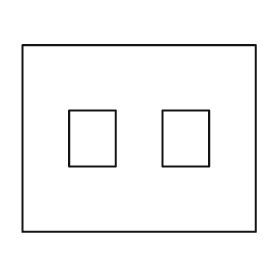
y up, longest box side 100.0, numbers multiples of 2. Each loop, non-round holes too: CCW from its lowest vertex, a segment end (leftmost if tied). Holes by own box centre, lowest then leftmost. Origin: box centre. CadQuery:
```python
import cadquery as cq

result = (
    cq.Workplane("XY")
    .moveTo(-50.0, -40.0)
    .lineTo(50.0, -40.0)
    .lineTo(50.0, 40.0)
    .lineTo(-50.0, 40.0)
    .close()
    .moveTo(-30.0, -12.0)
    .lineTo(-10.0, -12.0)
    .lineTo(-10.0, 12.0)
    .lineTo(-30.0, 12.0)
    .close()
    .moveTo(10.0, -12.0)
    .lineTo(30.0, -12.0)
    .lineTo(30.0, 12.0)
    .lineTo(10.0, 12.0)
    .close()
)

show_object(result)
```